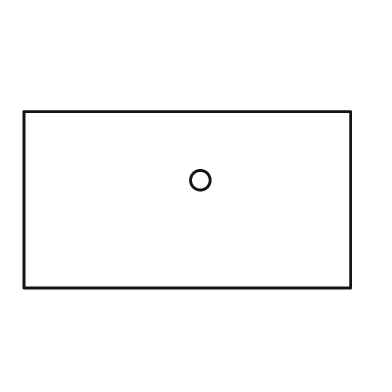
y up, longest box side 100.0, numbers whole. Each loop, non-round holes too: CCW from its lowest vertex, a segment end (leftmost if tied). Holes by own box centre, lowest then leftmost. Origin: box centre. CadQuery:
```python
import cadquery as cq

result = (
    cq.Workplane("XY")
    .moveTo(-50.0, -27.0)
    .lineTo(50.0, -27.0)
    .lineTo(50.0, 27.0)
    .lineTo(-50.0, 27.0)
    .close()
    .moveTo(4.0, 6.0)
    .circle(3.0)
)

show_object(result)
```